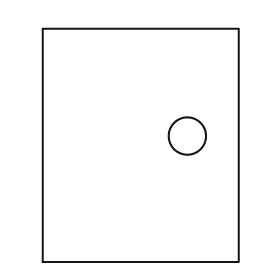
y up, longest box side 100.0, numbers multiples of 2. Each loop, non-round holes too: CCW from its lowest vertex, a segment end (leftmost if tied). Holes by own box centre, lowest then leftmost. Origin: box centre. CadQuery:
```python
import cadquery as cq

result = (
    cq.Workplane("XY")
    .moveTo(-42.0, -50.0)
    .lineTo(42.0, -50.0)
    .lineTo(42.0, 50.0)
    .lineTo(-42.0, 50.0)
    .close()
    .moveTo(20.0, 4.0)
    .circle(8.0)
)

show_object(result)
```